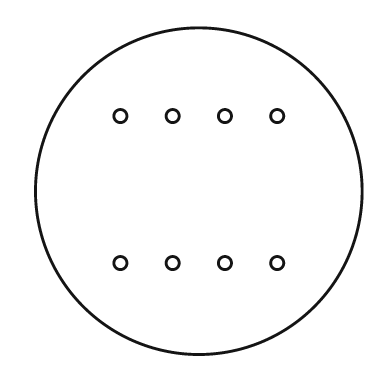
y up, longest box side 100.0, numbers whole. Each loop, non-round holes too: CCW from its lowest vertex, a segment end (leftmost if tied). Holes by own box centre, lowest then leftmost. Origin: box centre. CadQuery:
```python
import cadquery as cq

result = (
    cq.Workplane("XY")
    .moveTo(0.0, 0.0)
    .circle(50.0)
    .moveTo(-24.0, -22.0)
    .circle(2.0)
    .moveTo(-8.0, -22.0)
    .circle(2.0)
    .moveTo(8.0, -22.0)
    .circle(2.0)
    .moveTo(24.0, -22.0)
    .circle(2.0)
    .moveTo(-24.0, 23.0)
    .circle(2.0)
    .moveTo(-8.0, 23.0)
    .circle(2.0)
    .moveTo(8.0, 23.0)
    .circle(2.0)
    .moveTo(24.0, 23.0)
    .circle(2.0)
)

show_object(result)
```